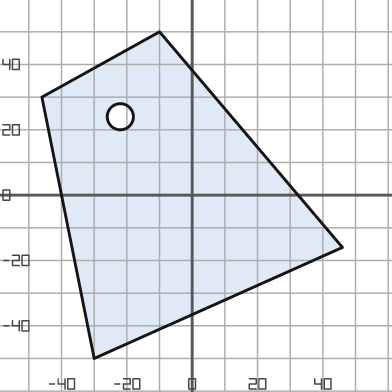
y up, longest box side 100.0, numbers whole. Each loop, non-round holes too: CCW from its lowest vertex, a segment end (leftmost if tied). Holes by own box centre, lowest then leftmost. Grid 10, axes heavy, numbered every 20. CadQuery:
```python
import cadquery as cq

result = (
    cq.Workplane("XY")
    .moveTo(-30.0, -50.0)
    .lineTo(46.0, -16.0)
    .lineTo(-10.0, 50.0)
    .lineTo(-46.0, 30.0)
    .close()
    .moveTo(-22.0, 24.0)
    .circle(4.0)
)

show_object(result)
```